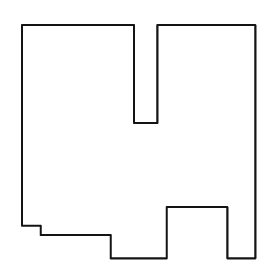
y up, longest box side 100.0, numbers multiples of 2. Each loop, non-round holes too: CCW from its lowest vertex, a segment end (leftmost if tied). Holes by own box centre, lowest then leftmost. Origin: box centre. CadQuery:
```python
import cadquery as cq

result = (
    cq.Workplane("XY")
    .moveTo(-12.0, -50.0)
    .lineTo(12.0, -50.0)
    .lineTo(12.0, -28.0)
    .lineTo(38.0, -28.0)
    .lineTo(38.0, -50.0)
    .lineTo(50.0, -50.0)
    .lineTo(50.0, 50.0)
    .lineTo(8.0, 50.0)
    .lineTo(8.0, 8.0)
    .lineTo(-2.0, 8.0)
    .lineTo(-2.0, 50.0)
    .lineTo(-50.0, 50.0)
    .lineTo(-50.0, -36.0)
    .lineTo(-42.0, -36.0)
    .lineTo(-42.0, -40.0)
    .lineTo(-12.0, -40.0)
    .close()
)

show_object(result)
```